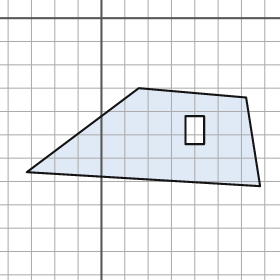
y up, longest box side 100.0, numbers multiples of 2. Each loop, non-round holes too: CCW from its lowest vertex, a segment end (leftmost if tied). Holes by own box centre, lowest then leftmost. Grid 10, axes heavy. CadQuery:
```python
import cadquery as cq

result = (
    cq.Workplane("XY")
    .moveTo(68.0, -72.0)
    .lineTo(62.0, -34.0)
    .lineTo(16.0, -30.0)
    .lineTo(-32.0, -66.0)
    .close()
    .moveTo(36.0, -54.0)
    .lineTo(44.0, -54.0)
    .lineTo(44.0, -42.0)
    .lineTo(36.0, -42.0)
    .close()
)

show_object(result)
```